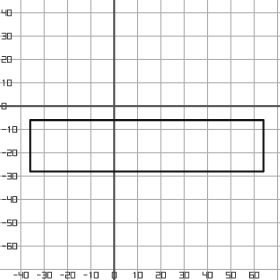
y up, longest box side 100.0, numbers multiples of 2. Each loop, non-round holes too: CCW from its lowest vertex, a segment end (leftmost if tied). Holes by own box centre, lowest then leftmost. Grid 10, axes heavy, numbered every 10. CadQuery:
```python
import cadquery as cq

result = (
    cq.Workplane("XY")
    .moveTo(-36.0, -28.0)
    .lineTo(64.0, -28.0)
    .lineTo(64.0, -6.0)
    .lineTo(-36.0, -6.0)
    .close()
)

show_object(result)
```